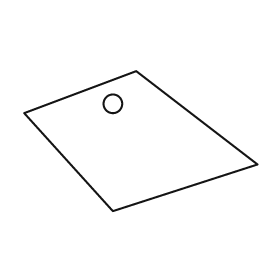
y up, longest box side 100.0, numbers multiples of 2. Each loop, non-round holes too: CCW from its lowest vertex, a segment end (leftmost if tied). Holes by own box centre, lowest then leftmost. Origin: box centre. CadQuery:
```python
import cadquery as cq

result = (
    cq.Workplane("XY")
    .moveTo(-12.0, -30.0)
    .lineTo(50.0, -10.0)
    .lineTo(-2.0, 30.0)
    .lineTo(-50.0, 12.0)
    .close()
    .moveTo(-12.0, 16.0)
    .circle(4.0)
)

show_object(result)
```